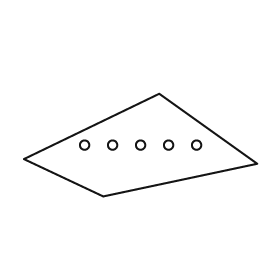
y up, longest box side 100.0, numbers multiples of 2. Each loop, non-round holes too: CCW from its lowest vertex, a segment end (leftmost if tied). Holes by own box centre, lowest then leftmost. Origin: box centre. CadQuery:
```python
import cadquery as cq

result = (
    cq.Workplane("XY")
    .moveTo(-16.0, -22.0)
    .lineTo(50.0, -8.0)
    .lineTo(8.0, 22.0)
    .lineTo(-50.0, -6.0)
    .close()
    .moveTo(-24.0, 0.0)
    .circle(2.0)
    .moveTo(-12.0, 0.0)
    .circle(2.0)
    .moveTo(0.0, 0.0)
    .circle(2.0)
    .moveTo(12.0, 0.0)
    .circle(2.0)
    .moveTo(24.0, 0.0)
    .circle(2.0)
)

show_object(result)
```